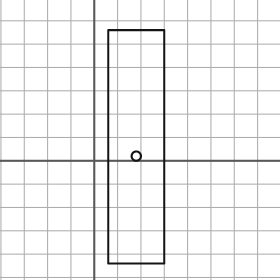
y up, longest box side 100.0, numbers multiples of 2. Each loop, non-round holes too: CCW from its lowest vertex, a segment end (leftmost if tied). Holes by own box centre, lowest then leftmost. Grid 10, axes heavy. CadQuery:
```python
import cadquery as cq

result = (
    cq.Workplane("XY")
    .moveTo(6.0, -44.0)
    .lineTo(30.0, -44.0)
    .lineTo(30.0, 56.0)
    .lineTo(6.0, 56.0)
    .close()
    .moveTo(18.0, 2.0)
    .circle(2.0)
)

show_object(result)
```